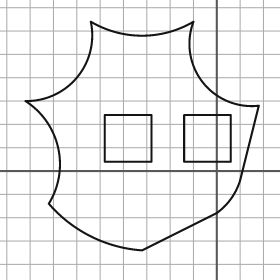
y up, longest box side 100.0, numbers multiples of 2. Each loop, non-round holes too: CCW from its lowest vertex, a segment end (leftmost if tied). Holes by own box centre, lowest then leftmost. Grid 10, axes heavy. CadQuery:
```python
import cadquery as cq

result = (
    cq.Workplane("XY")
    .moveTo(-32.0, -34.0)
    .lineTo(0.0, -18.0)
    .threePointArc((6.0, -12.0), (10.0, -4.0))
    .lineTo(18.0, 28.0)
    .threePointArc((-6.0, 38.0), (-10.0, 64.0))
    .threePointArc((-32.0, 58.0), (-54.0, 64.0))
    .threePointArc((-60.0, 40.0), (-82.0, 30.0))
    .threePointArc((-68.0, 10.0), (-72.0, -14.0))
    .threePointArc((-54.0, -28.0), (-32.0, -34.0))
    .close()
    .moveTo(-48.0, 4.0)
    .lineTo(-28.0, 4.0)
    .lineTo(-28.0, 24.0)
    .lineTo(-48.0, 24.0)
    .close()
    .moveTo(-14.0, 4.0)
    .lineTo(6.0, 4.0)
    .lineTo(6.0, 24.0)
    .lineTo(-14.0, 24.0)
    .close()
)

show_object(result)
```